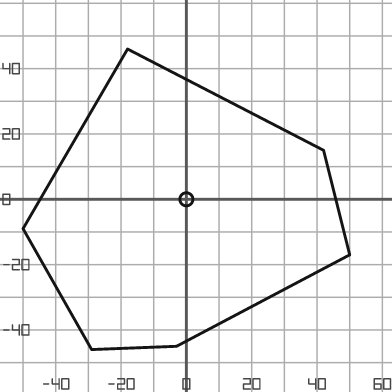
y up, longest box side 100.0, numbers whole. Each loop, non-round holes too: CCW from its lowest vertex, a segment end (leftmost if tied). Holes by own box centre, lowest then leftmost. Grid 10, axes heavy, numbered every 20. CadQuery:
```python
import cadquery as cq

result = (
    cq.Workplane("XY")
    .moveTo(-29.0, -46.0)
    .lineTo(-3.0, -45.0)
    .lineTo(50.0, -17.0)
    .lineTo(42.0, 15.0)
    .lineTo(-18.0, 46.0)
    .lineTo(-50.0, -9.0)
    .close()
    .moveTo(0.0, 0.0)
    .circle(2.0)
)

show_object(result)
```